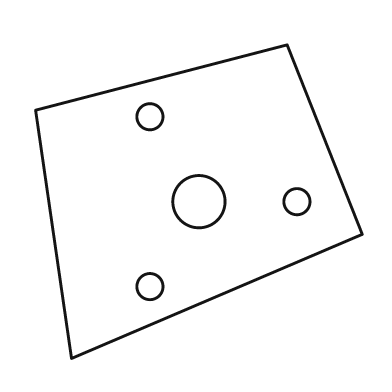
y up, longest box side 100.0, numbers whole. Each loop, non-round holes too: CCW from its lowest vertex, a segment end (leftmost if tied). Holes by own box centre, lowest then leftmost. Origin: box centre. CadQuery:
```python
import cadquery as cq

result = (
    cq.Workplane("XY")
    .moveTo(-39.0, -48.0)
    .lineTo(50.0, -10.0)
    .lineTo(27.0, 48.0)
    .lineTo(-50.0, 28.0)
    .close()
    .moveTo(-15.0, -26.0)
    .circle(4.0)
    .moveTo(0.0, 0.0)
    .circle(8.0)
    .moveTo(30.0, 0.0)
    .circle(4.0)
    .moveTo(-15.0, 26.0)
    .circle(4.0)
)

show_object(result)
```